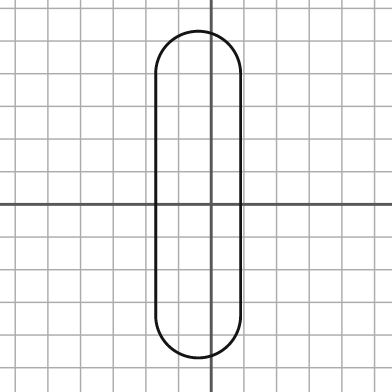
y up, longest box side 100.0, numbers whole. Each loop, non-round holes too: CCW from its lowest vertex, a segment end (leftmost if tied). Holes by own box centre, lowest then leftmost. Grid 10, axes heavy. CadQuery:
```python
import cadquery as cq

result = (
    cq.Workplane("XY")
    .moveTo(-17.0, -34.0)
    .threePointArc((-4.0, -47.0), (9.0, -34.0))
    .lineTo(9.0, 40.0)
    .threePointArc((-4.0, 53.0), (-17.0, 40.0))
    .close()
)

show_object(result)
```